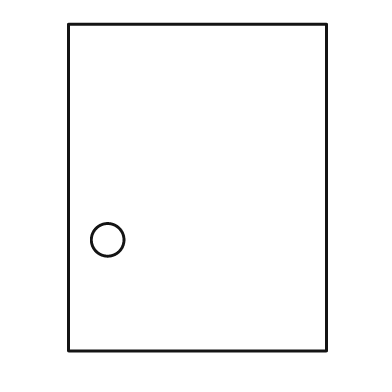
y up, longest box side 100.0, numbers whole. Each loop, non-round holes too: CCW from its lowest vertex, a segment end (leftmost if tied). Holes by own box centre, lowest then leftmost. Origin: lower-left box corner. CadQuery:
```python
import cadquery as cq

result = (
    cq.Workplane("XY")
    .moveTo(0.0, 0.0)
    .lineTo(79.0, 0.0)
    .lineTo(79.0, 100.0)
    .lineTo(0.0, 100.0)
    .close()
    .moveTo(12.0, 34.0)
    .circle(5.0)
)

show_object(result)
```